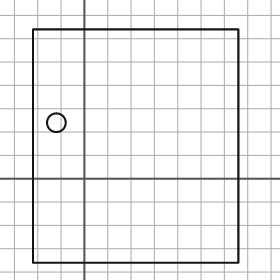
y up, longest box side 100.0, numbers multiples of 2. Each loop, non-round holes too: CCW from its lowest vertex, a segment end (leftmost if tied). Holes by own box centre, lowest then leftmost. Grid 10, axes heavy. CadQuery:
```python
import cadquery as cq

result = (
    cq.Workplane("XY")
    .moveTo(-22.0, -36.0)
    .lineTo(66.0, -36.0)
    .lineTo(66.0, 64.0)
    .lineTo(-22.0, 64.0)
    .close()
    .moveTo(-12.0, 24.0)
    .circle(4.0)
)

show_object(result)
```